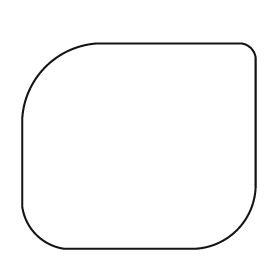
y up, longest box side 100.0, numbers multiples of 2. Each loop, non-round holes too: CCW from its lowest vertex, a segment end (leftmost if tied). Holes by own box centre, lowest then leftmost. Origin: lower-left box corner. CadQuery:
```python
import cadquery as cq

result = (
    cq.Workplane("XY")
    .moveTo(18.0, 0.0)
    .lineTo(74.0, 0.0)
    .threePointArc((92.0, 8.0), (100.0, 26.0))
    .lineTo(100.0, 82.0)
    .threePointArc((98.0, 86.0), (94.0, 88.0))
    .lineTo(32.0, 88.0)
    .threePointArc((10.0, 78.0), (0.0, 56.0))
    .lineTo(0.0, 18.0)
    .threePointArc((6.0, 6.0), (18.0, 0.0))
    .close()
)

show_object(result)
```